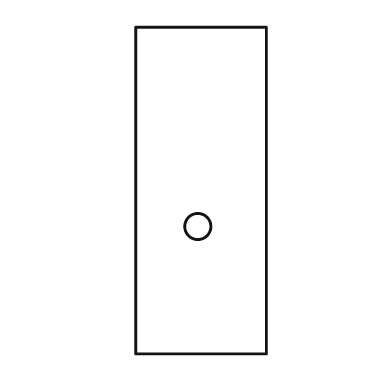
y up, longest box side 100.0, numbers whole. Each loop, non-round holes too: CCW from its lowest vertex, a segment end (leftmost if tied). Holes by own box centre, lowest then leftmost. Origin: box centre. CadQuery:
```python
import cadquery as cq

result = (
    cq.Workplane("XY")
    .moveTo(-20.0, -50.0)
    .lineTo(20.0, -50.0)
    .lineTo(20.0, 50.0)
    .lineTo(-20.0, 50.0)
    .close()
    .moveTo(-1.0, -11.0)
    .circle(4.0)
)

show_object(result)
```